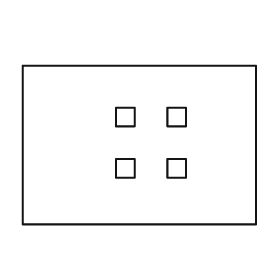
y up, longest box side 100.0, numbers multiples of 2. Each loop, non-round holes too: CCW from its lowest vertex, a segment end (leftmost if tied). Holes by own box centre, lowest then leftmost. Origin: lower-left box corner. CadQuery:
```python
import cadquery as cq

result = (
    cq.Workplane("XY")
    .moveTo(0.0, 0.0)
    .lineTo(100.0, 0.0)
    .lineTo(100.0, 68.0)
    .lineTo(0.0, 68.0)
    .close()
    .moveTo(40.0, 20.0)
    .lineTo(48.0, 20.0)
    .lineTo(48.0, 28.0)
    .lineTo(40.0, 28.0)
    .close()
    .moveTo(62.0, 20.0)
    .lineTo(70.0, 20.0)
    .lineTo(70.0, 28.0)
    .lineTo(62.0, 28.0)
    .close()
    .moveTo(40.0, 42.0)
    .lineTo(48.0, 42.0)
    .lineTo(48.0, 50.0)
    .lineTo(40.0, 50.0)
    .close()
    .moveTo(62.0, 42.0)
    .lineTo(70.0, 42.0)
    .lineTo(70.0, 50.0)
    .lineTo(62.0, 50.0)
    .close()
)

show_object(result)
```